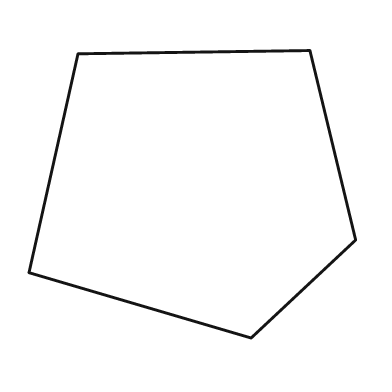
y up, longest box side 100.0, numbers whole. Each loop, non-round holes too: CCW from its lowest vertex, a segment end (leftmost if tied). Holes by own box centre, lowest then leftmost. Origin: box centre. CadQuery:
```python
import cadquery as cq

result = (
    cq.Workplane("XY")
    .moveTo(18.0, -44.0)
    .lineTo(50.0, -14.0)
    .lineTo(36.0, 44.0)
    .lineTo(-35.0, 43.0)
    .lineTo(-50.0, -24.0)
    .close()
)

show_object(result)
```